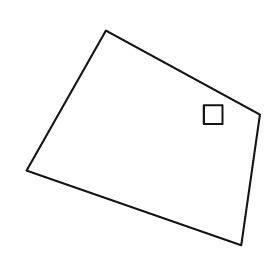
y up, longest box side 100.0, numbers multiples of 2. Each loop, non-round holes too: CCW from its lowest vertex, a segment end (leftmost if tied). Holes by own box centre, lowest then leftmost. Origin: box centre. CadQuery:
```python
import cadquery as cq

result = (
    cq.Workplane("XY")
    .moveTo(42.0, -46.0)
    .lineTo(50.0, 10.0)
    .lineTo(-16.0, 46.0)
    .lineTo(-50.0, -14.0)
    .close()
    .moveTo(26.0, 6.0)
    .lineTo(34.0, 6.0)
    .lineTo(34.0, 14.0)
    .lineTo(26.0, 14.0)
    .close()
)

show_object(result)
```